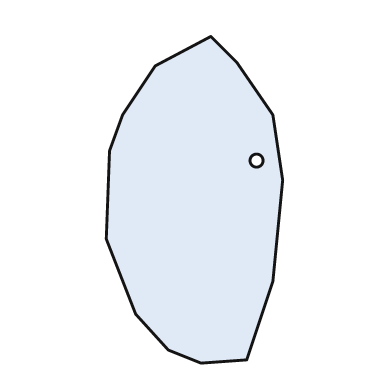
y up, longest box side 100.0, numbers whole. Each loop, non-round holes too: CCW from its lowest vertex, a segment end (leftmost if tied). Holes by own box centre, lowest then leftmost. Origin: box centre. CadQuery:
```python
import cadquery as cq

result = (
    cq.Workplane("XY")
    .moveTo(2.0, -50.0)
    .lineTo(16.0, -49.0)
    .lineTo(24.0, -25.0)
    .lineTo(27.0, 6.0)
    .lineTo(24.0, 26.0)
    .lineTo(13.0, 42.0)
    .lineTo(5.0, 50.0)
    .lineTo(-12.0, 41.0)
    .lineTo(-22.0, 26.0)
    .lineTo(-26.0, 15.0)
    .lineTo(-27.0, -12.0)
    .lineTo(-18.0, -35.0)
    .lineTo(-8.0, -46.0)
    .close()
    .moveTo(19.0, 12.0)
    .circle(2.0)
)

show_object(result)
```